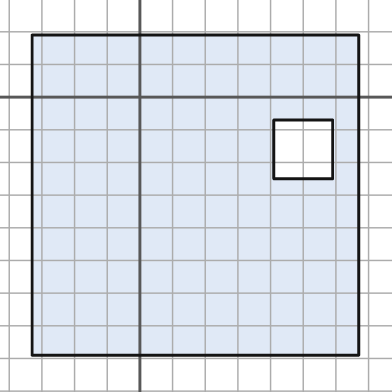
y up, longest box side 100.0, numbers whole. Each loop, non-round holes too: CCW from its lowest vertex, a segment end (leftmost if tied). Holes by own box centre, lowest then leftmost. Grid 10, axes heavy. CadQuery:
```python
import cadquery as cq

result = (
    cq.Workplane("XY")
    .moveTo(-33.0, -79.0)
    .lineTo(67.0, -79.0)
    .lineTo(67.0, 19.0)
    .lineTo(-33.0, 19.0)
    .close()
    .moveTo(41.0, -25.0)
    .lineTo(59.0, -25.0)
    .lineTo(59.0, -7.0)
    .lineTo(41.0, -7.0)
    .close()
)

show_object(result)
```